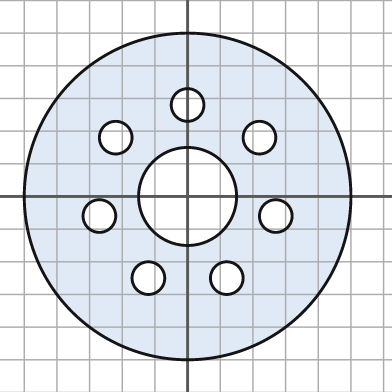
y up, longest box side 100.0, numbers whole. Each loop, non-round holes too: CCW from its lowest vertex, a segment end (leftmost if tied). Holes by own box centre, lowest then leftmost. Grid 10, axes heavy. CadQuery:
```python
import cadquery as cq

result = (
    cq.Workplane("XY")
    .moveTo(0.0, 0.0)
    .circle(50.0)
    .moveTo(-12.0, -25.0)
    .circle(5.0)
    .moveTo(12.0, -25.0)
    .circle(5.0)
    .moveTo(-27.0, -6.0)
    .circle(5.0)
    .moveTo(27.0, -6.0)
    .circle(5.0)
    .moveTo(0.0, 0.0)
    .circle(15.0)
    .moveTo(-22.0, 18.0)
    .circle(5.0)
    .moveTo(22.0, 18.0)
    .circle(5.0)
    .moveTo(0.0, 28.0)
    .circle(5.0)
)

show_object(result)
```